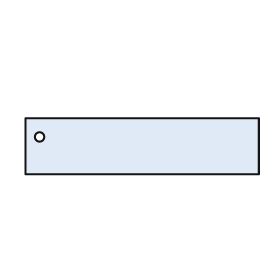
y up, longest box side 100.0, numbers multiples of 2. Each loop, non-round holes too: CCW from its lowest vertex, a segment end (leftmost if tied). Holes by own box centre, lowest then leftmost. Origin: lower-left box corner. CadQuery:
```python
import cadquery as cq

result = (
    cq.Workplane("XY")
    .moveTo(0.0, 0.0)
    .lineTo(100.0, 0.0)
    .lineTo(100.0, 24.0)
    .lineTo(0.0, 24.0)
    .close()
    .moveTo(6.0, 16.0)
    .circle(2.0)
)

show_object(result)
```